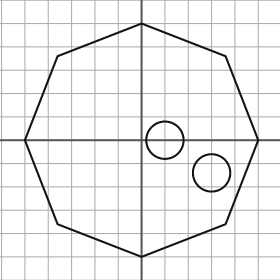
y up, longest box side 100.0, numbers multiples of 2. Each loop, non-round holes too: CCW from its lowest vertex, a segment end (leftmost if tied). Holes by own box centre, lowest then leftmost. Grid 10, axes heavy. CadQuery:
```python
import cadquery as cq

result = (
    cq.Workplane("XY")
    .moveTo(0.0, -50.0)
    .lineTo(36.0, -36.0)
    .lineTo(50.0, 0.0)
    .lineTo(36.0, 36.0)
    .lineTo(0.0, 50.0)
    .lineTo(-36.0, 36.0)
    .lineTo(-50.0, 0.0)
    .lineTo(-36.0, -36.0)
    .close()
    .moveTo(30.0, -14.0)
    .circle(8.0)
    .moveTo(10.0, 0.0)
    .circle(8.0)
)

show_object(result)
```